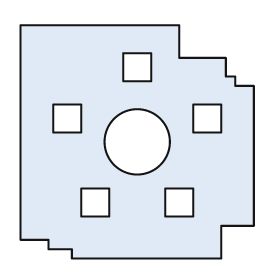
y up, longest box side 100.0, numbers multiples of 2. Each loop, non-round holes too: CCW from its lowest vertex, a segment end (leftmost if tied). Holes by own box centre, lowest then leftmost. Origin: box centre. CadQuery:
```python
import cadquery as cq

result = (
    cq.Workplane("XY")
    .moveTo(-28.0, -50.0)
    .lineTo(36.0, -50.0)
    .lineTo(36.0, -36.0)
    .lineTo(50.0, -36.0)
    .lineTo(50.0, 24.0)
    .lineTo(42.0, 24.0)
    .lineTo(42.0, 28.0)
    .lineTo(38.0, 28.0)
    .lineTo(38.0, 36.0)
    .lineTo(18.0, 36.0)
    .lineTo(18.0, 50.0)
    .lineTo(-50.0, 50.0)
    .lineTo(-50.0, -42.0)
    .lineTo(-38.0, -42.0)
    .lineTo(-38.0, -46.0)
    .lineTo(-28.0, -46.0)
    .close()
    .moveTo(-24.0, -32.0)
    .lineTo(-12.0, -32.0)
    .lineTo(-12.0, -20.0)
    .lineTo(-24.0, -20.0)
    .close()
    .moveTo(12.0, -32.0)
    .lineTo(24.0, -32.0)
    .lineTo(24.0, -20.0)
    .lineTo(12.0, -20.0)
    .close()
    .moveTo(0.0, 0.0)
    .circle(14.0)
    .moveTo(-36.0, 4.0)
    .lineTo(-24.0, 4.0)
    .lineTo(-24.0, 16.0)
    .lineTo(-36.0, 16.0)
    .close()
    .moveTo(24.0, 4.0)
    .lineTo(36.0, 4.0)
    .lineTo(36.0, 16.0)
    .lineTo(24.0, 16.0)
    .close()
    .moveTo(-6.0, 26.0)
    .lineTo(6.0, 26.0)
    .lineTo(6.0, 38.0)
    .lineTo(-6.0, 38.0)
    .close()
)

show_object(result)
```